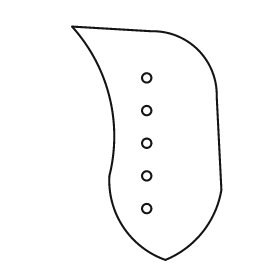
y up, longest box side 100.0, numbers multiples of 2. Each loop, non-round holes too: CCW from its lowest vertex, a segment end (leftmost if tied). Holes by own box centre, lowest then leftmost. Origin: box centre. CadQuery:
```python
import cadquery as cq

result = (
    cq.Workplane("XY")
    .moveTo(8.0, -50.0)
    .threePointArc((24.0, -38.0), (32.0, -20.0))
    .lineTo(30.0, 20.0)
    .threePointArc((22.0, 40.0), (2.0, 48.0))
    .lineTo(-32.0, 50.0)
    .threePointArc((-16.0, 20.0), (-16.0, -14.0))
    .threePointArc((-10.0, -36.0), (8.0, -50.0))
    .close()
    .moveTo(0.0, -28.0)
    .circle(2.0)
    .moveTo(0.0, -14.0)
    .circle(2.0)
    .moveTo(0.0, 0.0)
    .circle(2.0)
    .moveTo(0.0, 14.0)
    .circle(2.0)
    .moveTo(0.0, 28.0)
    .circle(2.0)
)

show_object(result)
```